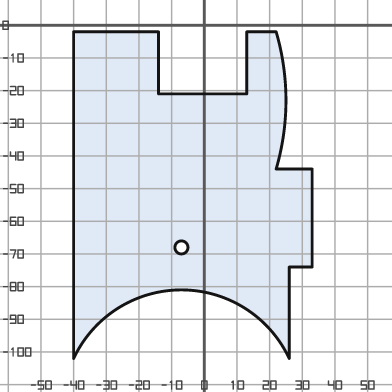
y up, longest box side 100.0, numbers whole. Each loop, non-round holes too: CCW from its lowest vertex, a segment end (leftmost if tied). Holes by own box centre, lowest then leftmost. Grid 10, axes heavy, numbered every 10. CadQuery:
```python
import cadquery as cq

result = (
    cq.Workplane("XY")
    .moveTo(-40.0, -102.0)
    .threePointArc((-7.0, -81.0), (26.0, -102.0))
    .lineTo(26.0, -74.0)
    .lineTo(33.0, -74.0)
    .lineTo(33.0, -44.0)
    .lineTo(22.0, -44.0)
    .threePointArc((25.0, -23.0), (22.0, -2.0))
    .lineTo(13.0, -2.0)
    .lineTo(13.0, -21.0)
    .lineTo(-14.0, -21.0)
    .lineTo(-14.0, -2.0)
    .lineTo(-40.0, -2.0)
    .close()
    .moveTo(-7.0, -68.0)
    .circle(2.0)
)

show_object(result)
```